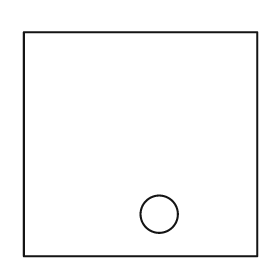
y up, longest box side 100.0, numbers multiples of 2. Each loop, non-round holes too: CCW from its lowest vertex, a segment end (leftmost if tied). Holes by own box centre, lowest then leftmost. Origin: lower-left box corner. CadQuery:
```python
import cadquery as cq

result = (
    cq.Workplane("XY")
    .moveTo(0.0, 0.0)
    .lineTo(100.0, 0.0)
    .lineTo(100.0, 96.0)
    .lineTo(0.0, 96.0)
    .close()
    .moveTo(58.0, 18.0)
    .circle(8.0)
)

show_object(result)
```